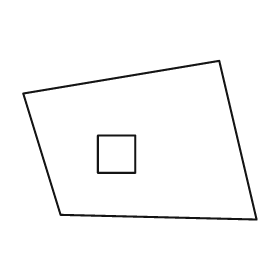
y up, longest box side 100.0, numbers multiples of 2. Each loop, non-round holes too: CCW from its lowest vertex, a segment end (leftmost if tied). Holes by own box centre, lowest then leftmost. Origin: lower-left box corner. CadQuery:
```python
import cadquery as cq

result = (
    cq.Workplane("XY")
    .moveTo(100.0, 0.0)
    .lineTo(84.0, 68.0)
    .lineTo(0.0, 54.0)
    .lineTo(16.0, 2.0)
    .close()
    .moveTo(32.0, 20.0)
    .lineTo(48.0, 20.0)
    .lineTo(48.0, 36.0)
    .lineTo(32.0, 36.0)
    .close()
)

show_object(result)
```